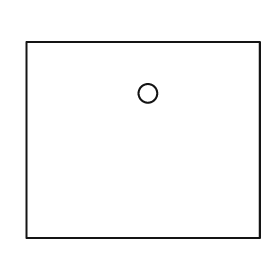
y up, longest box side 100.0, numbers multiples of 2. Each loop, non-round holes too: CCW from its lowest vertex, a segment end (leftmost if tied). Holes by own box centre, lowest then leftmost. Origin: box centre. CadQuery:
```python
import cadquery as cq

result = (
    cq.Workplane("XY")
    .moveTo(-50.0, -42.0)
    .lineTo(50.0, -42.0)
    .lineTo(50.0, 42.0)
    .lineTo(-50.0, 42.0)
    .close()
    .moveTo(2.0, 20.0)
    .circle(4.0)
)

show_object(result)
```